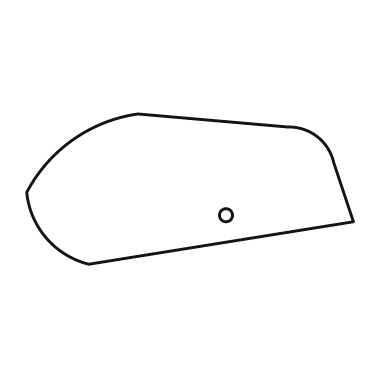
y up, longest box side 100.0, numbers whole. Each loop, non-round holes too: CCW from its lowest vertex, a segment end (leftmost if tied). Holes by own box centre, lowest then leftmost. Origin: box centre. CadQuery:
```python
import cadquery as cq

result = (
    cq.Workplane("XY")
    .moveTo(-31.0, -23.0)
    .lineTo(50.0, -10.0)
    .lineTo(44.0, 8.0)
    .threePointArc((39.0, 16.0), (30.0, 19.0))
    .lineTo(-16.0, 23.0)
    .threePointArc((-36.0, 15.0), (-50.0, -1.0))
    .threePointArc((-44.0, -15.0), (-31.0, -23.0))
    .close()
    .moveTo(11.0, -8.0)
    .circle(2.0)
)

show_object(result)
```